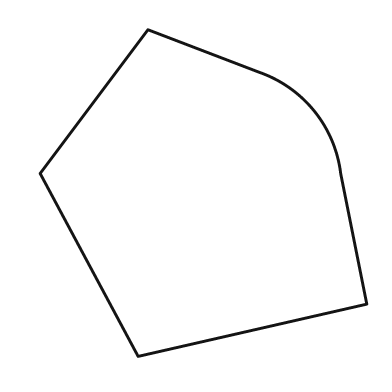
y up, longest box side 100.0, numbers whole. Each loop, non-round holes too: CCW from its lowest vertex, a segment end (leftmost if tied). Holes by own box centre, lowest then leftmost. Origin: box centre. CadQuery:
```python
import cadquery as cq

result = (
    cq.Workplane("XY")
    .moveTo(-20.0, -50.0)
    .lineTo(50.0, -34.0)
    .lineTo(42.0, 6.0)
    .threePointArc((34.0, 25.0), (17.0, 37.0))
    .lineTo(-17.0, 50.0)
    .lineTo(-50.0, 6.0)
    .close()
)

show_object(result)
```